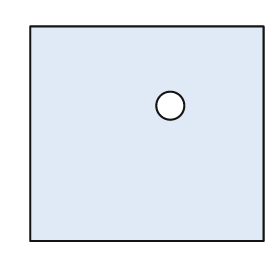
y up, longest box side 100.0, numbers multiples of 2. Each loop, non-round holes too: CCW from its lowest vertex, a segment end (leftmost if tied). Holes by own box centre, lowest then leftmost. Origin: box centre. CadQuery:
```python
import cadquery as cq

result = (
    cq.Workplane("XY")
    .moveTo(-50.0, -46.0)
    .lineTo(50.0, -46.0)
    .lineTo(50.0, 46.0)
    .lineTo(-50.0, 46.0)
    .close()
    .moveTo(10.0, 12.0)
    .circle(6.0)
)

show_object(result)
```